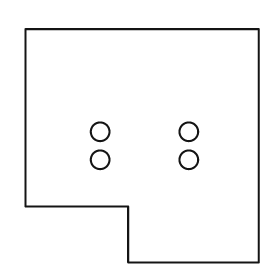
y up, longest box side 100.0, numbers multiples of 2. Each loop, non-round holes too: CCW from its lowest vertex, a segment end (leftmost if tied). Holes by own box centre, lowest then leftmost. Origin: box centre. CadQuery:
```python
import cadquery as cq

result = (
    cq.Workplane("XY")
    .moveTo(-6.0, -50.0)
    .lineTo(50.0, -50.0)
    .lineTo(50.0, 50.0)
    .lineTo(-50.0, 50.0)
    .lineTo(-50.0, -26.0)
    .lineTo(-6.0, -26.0)
    .close()
    .moveTo(-18.0, -6.0)
    .circle(4.0)
    .moveTo(20.0, -6.0)
    .circle(4.0)
    .moveTo(-18.0, 6.0)
    .circle(4.0)
    .moveTo(20.0, 6.0)
    .circle(4.0)
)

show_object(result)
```